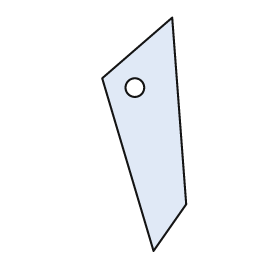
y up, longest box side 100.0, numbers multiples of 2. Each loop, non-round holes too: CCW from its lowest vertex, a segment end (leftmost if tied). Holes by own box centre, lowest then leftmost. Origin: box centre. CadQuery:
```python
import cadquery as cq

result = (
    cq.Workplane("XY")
    .moveTo(4.0, -50.0)
    .lineTo(18.0, -30.0)
    .lineTo(12.0, 50.0)
    .lineTo(-18.0, 24.0)
    .close()
    .moveTo(-4.0, 20.0)
    .circle(4.0)
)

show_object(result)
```